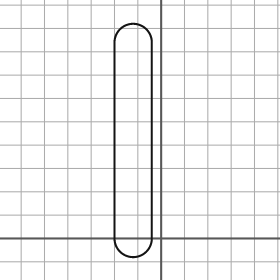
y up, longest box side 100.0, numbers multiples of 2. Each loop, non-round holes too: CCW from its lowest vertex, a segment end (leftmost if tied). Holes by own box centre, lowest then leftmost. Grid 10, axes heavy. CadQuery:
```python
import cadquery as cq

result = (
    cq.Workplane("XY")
    .moveTo(-20.0, 0.0)
    .threePointArc((-12.0, -8.0), (-4.0, 0.0))
    .lineTo(-4.0, 84.0)
    .threePointArc((-12.0, 92.0), (-20.0, 84.0))
    .close()
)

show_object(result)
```